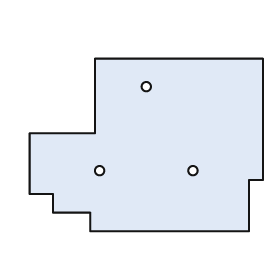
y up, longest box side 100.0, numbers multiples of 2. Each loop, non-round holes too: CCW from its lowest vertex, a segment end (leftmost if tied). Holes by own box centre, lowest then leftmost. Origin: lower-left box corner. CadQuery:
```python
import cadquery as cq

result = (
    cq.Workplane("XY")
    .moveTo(26.0, 0.0)
    .lineTo(94.0, 0.0)
    .lineTo(94.0, 22.0)
    .lineTo(100.0, 22.0)
    .lineTo(100.0, 74.0)
    .lineTo(28.0, 74.0)
    .lineTo(28.0, 42.0)
    .lineTo(0.0, 42.0)
    .lineTo(0.0, 16.0)
    .lineTo(10.0, 16.0)
    .lineTo(10.0, 8.0)
    .lineTo(26.0, 8.0)
    .close()
    .moveTo(30.0, 26.0)
    .circle(2.0)
    .moveTo(70.0, 26.0)
    .circle(2.0)
    .moveTo(50.0, 62.0)
    .circle(2.0)
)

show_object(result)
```